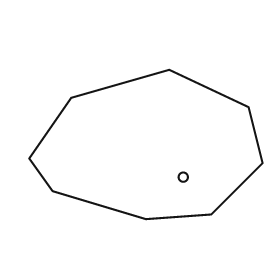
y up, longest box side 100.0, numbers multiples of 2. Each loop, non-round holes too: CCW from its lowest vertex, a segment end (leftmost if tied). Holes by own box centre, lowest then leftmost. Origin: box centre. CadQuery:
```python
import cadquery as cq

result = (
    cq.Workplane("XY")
    .moveTo(0.0, -32.0)
    .lineTo(28.0, -30.0)
    .lineTo(50.0, -8.0)
    .lineTo(44.0, 16.0)
    .lineTo(10.0, 32.0)
    .lineTo(-32.0, 20.0)
    .lineTo(-50.0, -6.0)
    .lineTo(-40.0, -20.0)
    .close()
    .moveTo(16.0, -14.0)
    .circle(2.0)
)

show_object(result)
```